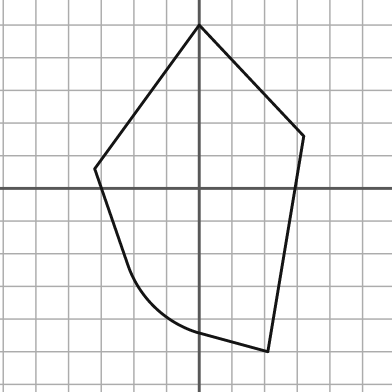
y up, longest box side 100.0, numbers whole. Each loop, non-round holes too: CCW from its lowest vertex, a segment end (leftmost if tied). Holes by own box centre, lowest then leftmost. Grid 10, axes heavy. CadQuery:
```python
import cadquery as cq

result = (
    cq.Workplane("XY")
    .moveTo(21.0, -50.0)
    .lineTo(32.0, 16.0)
    .lineTo(0.0, 50.0)
    .lineTo(-32.0, 6.0)
    .lineTo(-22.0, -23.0)
    .threePointArc((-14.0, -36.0), (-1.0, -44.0))
    .close()
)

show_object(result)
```